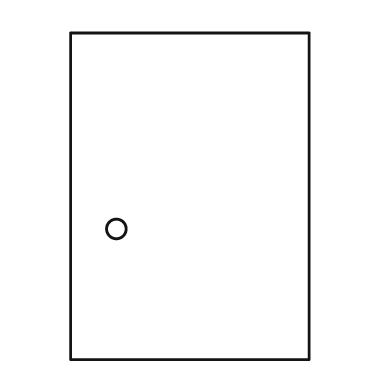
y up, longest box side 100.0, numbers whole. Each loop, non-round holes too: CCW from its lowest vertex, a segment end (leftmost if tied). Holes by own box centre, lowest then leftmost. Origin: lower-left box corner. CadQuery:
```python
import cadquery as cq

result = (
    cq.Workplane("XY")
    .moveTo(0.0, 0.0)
    .lineTo(73.0, 0.0)
    .lineTo(73.0, 100.0)
    .lineTo(0.0, 100.0)
    .close()
    .moveTo(14.0, 40.0)
    .circle(3.0)
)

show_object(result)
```